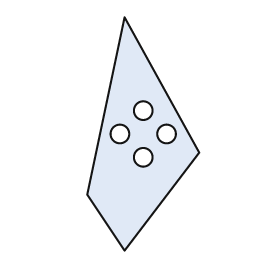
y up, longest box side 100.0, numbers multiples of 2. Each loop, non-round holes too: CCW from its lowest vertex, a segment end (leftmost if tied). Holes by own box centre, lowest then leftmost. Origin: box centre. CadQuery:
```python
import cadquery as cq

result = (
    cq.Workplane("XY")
    .moveTo(-8.0, -50.0)
    .lineTo(24.0, -8.0)
    .lineTo(-8.0, 50.0)
    .lineTo(-24.0, -26.0)
    .close()
    .moveTo(0.0, -10.0)
    .circle(4.0)
    .moveTo(-10.0, 0.0)
    .circle(4.0)
    .moveTo(10.0, 0.0)
    .circle(4.0)
    .moveTo(0.0, 10.0)
    .circle(4.0)
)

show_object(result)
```